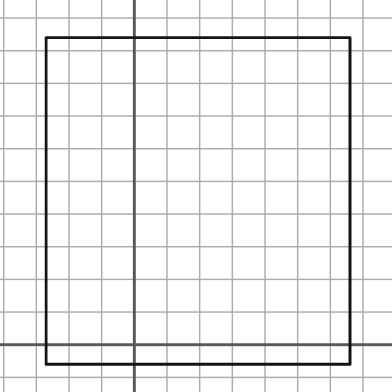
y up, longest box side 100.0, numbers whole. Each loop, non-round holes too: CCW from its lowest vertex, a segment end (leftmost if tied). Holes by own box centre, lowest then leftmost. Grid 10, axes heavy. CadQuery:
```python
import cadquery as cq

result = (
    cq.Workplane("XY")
    .moveTo(-27.0, -6.0)
    .lineTo(66.0, -6.0)
    .lineTo(66.0, 94.0)
    .lineTo(-27.0, 94.0)
    .close()
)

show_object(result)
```